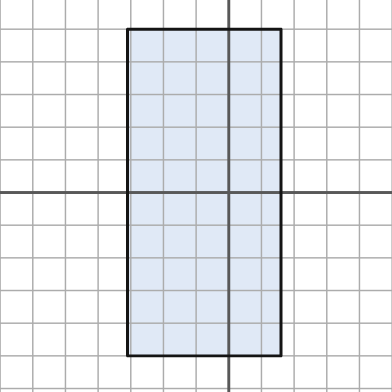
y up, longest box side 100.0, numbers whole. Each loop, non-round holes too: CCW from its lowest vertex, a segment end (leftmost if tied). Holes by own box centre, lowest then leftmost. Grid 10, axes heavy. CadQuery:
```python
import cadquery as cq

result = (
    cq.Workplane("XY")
    .moveTo(-31.0, -50.0)
    .lineTo(16.0, -50.0)
    .lineTo(16.0, 50.0)
    .lineTo(-31.0, 50.0)
    .close()
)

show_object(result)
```